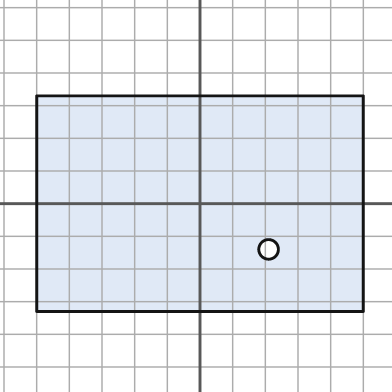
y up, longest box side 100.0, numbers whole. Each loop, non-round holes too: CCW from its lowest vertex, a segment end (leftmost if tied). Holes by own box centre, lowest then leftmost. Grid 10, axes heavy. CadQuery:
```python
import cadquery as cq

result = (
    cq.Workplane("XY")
    .moveTo(-50.0, -33.0)
    .lineTo(50.0, -33.0)
    .lineTo(50.0, 33.0)
    .lineTo(-50.0, 33.0)
    .close()
    .moveTo(21.0, -14.0)
    .circle(3.0)
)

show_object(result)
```